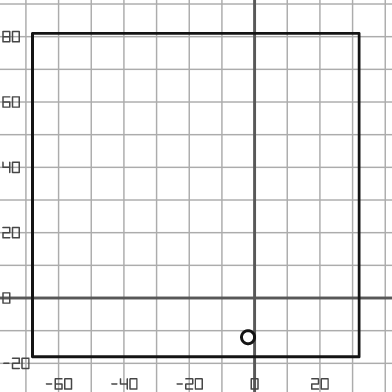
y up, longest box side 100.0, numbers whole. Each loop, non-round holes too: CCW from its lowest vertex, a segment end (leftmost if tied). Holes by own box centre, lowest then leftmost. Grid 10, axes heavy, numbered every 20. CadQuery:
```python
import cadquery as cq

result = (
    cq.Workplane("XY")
    .moveTo(-68.0, -18.0)
    .lineTo(32.0, -18.0)
    .lineTo(32.0, 81.0)
    .lineTo(-68.0, 81.0)
    .close()
    .moveTo(-2.0, -12.0)
    .circle(2.0)
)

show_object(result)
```